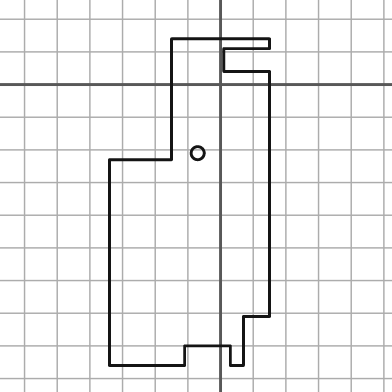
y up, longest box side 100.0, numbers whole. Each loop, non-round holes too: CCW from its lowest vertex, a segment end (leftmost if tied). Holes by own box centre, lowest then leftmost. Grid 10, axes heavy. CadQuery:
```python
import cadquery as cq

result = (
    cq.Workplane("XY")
    .moveTo(-34.0, -86.0)
    .lineTo(-11.0, -86.0)
    .lineTo(-11.0, -80.0)
    .lineTo(3.0, -80.0)
    .lineTo(3.0, -86.0)
    .lineTo(7.0, -86.0)
    .lineTo(7.0, -71.0)
    .lineTo(15.0, -71.0)
    .lineTo(15.0, 4.0)
    .lineTo(1.0, 4.0)
    .lineTo(1.0, 11.0)
    .lineTo(15.0, 11.0)
    .lineTo(15.0, 14.0)
    .lineTo(-15.0, 14.0)
    .lineTo(-15.0, -23.0)
    .lineTo(-34.0, -23.0)
    .close()
    .moveTo(-7.0, -21.0)
    .circle(2.0)
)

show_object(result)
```